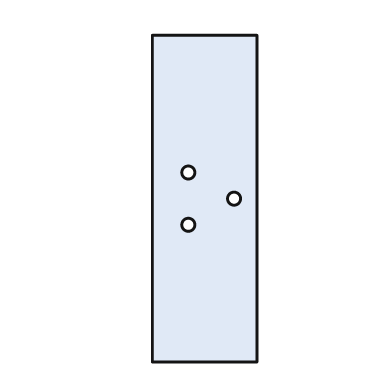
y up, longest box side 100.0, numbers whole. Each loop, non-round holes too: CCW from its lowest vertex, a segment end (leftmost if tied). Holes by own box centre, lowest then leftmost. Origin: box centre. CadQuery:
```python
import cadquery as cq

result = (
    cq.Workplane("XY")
    .moveTo(-16.0, -50.0)
    .lineTo(16.0, -50.0)
    .lineTo(16.0, 50.0)
    .lineTo(-16.0, 50.0)
    .close()
    .moveTo(-5.0, -8.0)
    .circle(2.0)
    .moveTo(9.0, 0.0)
    .circle(2.0)
    .moveTo(-5.0, 8.0)
    .circle(2.0)
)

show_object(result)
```